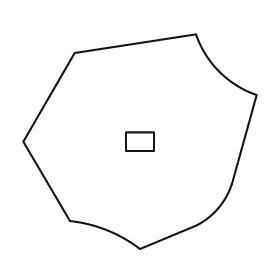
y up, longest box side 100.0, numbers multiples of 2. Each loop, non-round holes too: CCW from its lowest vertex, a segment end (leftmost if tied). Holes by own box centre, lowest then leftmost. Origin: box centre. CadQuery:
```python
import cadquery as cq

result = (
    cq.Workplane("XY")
    .moveTo(0.0, -46.0)
    .lineTo(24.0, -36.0)
    .threePointArc((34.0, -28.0), (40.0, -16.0))
    .lineTo(50.0, 20.0)
    .threePointArc((34.0, 30.0), (24.0, 46.0))
    .lineTo(-28.0, 38.0)
    .lineTo(-50.0, 0.0)
    .lineTo(-30.0, -34.0)
    .threePointArc((-14.0, -38.0), (0.0, -46.0))
    .close()
    .moveTo(-6.0, -4.0)
    .lineTo(6.0, -4.0)
    .lineTo(6.0, 4.0)
    .lineTo(-6.0, 4.0)
    .close()
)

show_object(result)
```